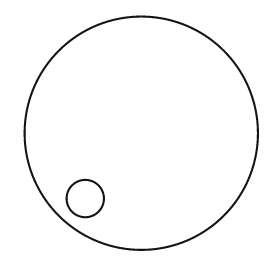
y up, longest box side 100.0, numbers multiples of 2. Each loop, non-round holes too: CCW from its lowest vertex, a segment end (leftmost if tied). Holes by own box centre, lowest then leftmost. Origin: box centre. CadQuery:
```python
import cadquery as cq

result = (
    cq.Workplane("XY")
    .moveTo(0.0, 0.0)
    .circle(50.0)
    .moveTo(-24.0, -28.0)
    .circle(8.0)
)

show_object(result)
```